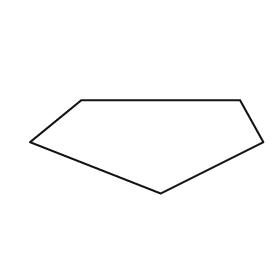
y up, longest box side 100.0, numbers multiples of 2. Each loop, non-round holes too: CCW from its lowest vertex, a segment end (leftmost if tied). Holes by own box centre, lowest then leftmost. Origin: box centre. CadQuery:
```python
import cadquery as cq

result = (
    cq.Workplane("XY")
    .moveTo(6.0, -20.0)
    .lineTo(50.0, 2.0)
    .lineTo(40.0, 20.0)
    .lineTo(-28.0, 20.0)
    .lineTo(-50.0, 2.0)
    .close()
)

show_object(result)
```